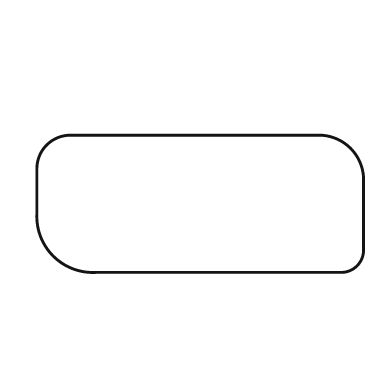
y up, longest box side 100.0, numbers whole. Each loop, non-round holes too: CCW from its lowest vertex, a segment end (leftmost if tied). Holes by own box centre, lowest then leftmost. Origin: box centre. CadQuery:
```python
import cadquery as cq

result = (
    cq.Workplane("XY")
    .moveTo(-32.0, -21.0)
    .lineTo(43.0, -21.0)
    .threePointArc((48.0, -19.0), (50.0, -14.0))
    .lineTo(50.0, 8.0)
    .threePointArc((46.0, 17.0), (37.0, 21.0))
    .lineTo(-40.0, 21.0)
    .threePointArc((-47.0, 18.0), (-50.0, 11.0))
    .lineTo(-50.0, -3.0)
    .threePointArc((-45.0, -16.0), (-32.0, -21.0))
    .close()
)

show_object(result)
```